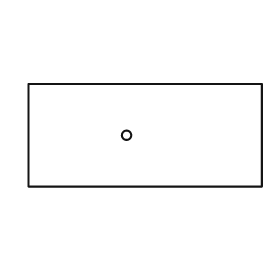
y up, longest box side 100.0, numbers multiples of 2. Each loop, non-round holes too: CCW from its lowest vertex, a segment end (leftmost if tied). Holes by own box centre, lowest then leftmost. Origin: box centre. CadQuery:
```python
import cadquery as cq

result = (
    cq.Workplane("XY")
    .moveTo(-50.0, -22.0)
    .lineTo(50.0, -22.0)
    .lineTo(50.0, 22.0)
    .lineTo(-50.0, 22.0)
    .close()
    .moveTo(-8.0, 0.0)
    .circle(2.0)
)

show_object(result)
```